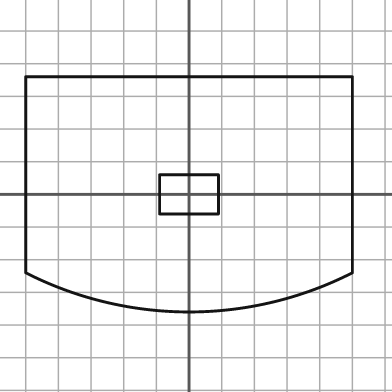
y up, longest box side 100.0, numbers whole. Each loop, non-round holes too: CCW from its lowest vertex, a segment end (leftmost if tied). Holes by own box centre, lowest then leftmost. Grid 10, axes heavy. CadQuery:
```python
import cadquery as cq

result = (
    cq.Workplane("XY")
    .moveTo(-50.0, -24.0)
    .threePointArc((0.0, -36.0), (50.0, -24.0))
    .lineTo(50.0, 36.0)
    .lineTo(-50.0, 36.0)
    .close()
    .moveTo(-9.0, -6.0)
    .lineTo(9.0, -6.0)
    .lineTo(9.0, 6.0)
    .lineTo(-9.0, 6.0)
    .close()
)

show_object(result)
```